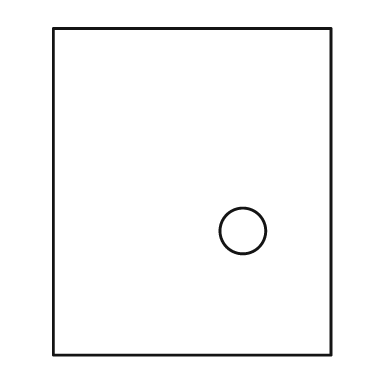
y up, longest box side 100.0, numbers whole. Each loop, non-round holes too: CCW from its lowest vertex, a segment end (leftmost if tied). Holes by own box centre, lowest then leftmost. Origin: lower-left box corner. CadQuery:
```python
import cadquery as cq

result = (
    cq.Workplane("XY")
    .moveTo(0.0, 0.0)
    .lineTo(85.0, 0.0)
    .lineTo(85.0, 100.0)
    .lineTo(0.0, 100.0)
    .close()
    .moveTo(58.0, 38.0)
    .circle(7.0)
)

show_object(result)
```